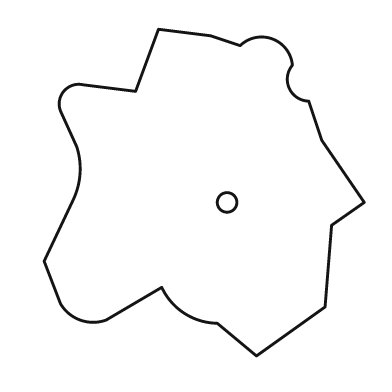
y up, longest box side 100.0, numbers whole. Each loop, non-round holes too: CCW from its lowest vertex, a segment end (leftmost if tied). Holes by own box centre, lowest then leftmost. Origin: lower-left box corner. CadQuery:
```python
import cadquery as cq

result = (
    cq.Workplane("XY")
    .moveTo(65.0, 0.0)
    .lineTo(86.0, 15.0)
    .lineTo(88.0, 40.0)
    .lineTo(98.0, 47.0)
    .lineTo(85.0, 66.0)
    .lineTo(81.0, 78.0)
    .threePointArc((75.0, 82.0), (76.0, 89.0))
    .threePointArc((70.0, 97.0), (60.0, 95.0))
    .lineTo(51.0, 98.0)
    .lineTo(35.0, 100.0)
    .lineTo(28.0, 81.0)
    .lineTo(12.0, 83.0)
    .threePointArc((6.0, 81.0), (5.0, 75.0))
    .lineTo(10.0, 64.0)
    .threePointArc((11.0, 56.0), (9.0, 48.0))
    .lineTo(0.0, 29.0)
    .lineTo(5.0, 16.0)
    .threePointArc((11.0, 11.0), (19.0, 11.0))
    .lineTo(36.0, 21.0)
    .threePointArc((43.0, 13.0), (53.0, 10.0))
    .close()
    .moveTo(56.0, 47.0)
    .circle(3.0)
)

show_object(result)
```